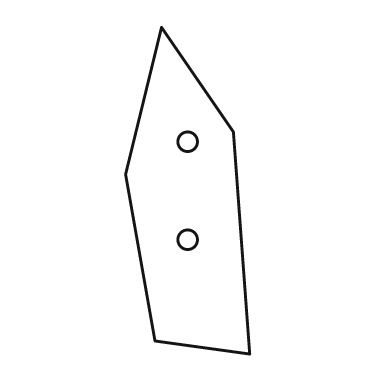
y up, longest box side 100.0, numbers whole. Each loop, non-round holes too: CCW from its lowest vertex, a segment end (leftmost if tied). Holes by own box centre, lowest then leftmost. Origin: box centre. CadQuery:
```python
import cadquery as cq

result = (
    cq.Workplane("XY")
    .moveTo(19.0, -50.0)
    .lineTo(14.0, 18.0)
    .lineTo(-8.0, 50.0)
    .lineTo(-19.0, 5.0)
    .lineTo(-10.0, -46.0)
    .close()
    .moveTo(0.0, -15.0)
    .circle(3.0)
    .moveTo(0.0, 15.0)
    .circle(3.0)
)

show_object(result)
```